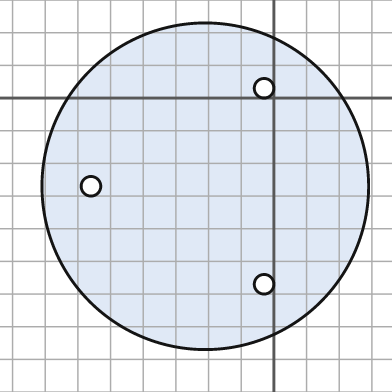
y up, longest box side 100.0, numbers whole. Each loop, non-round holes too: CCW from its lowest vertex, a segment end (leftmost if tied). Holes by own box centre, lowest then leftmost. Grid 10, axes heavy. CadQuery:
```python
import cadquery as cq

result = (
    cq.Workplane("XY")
    .moveTo(-21.0, -27.0)
    .circle(50.0)
    .moveTo(-3.0, -57.0)
    .circle(3.0)
    .moveTo(-56.0, -27.0)
    .circle(3.0)
    .moveTo(-3.0, 3.0)
    .circle(3.0)
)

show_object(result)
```